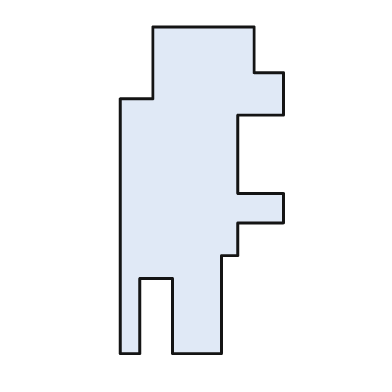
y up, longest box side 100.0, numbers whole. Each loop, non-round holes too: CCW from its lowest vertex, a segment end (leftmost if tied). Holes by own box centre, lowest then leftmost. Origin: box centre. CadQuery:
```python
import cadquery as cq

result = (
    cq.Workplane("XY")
    .moveTo(-25.0, -50.0)
    .lineTo(-19.0, -50.0)
    .lineTo(-19.0, -27.0)
    .lineTo(-9.0, -27.0)
    .lineTo(-9.0, -50.0)
    .lineTo(6.0, -50.0)
    .lineTo(6.0, -20.0)
    .lineTo(11.0, -20.0)
    .lineTo(11.0, -10.0)
    .lineTo(25.0, -10.0)
    .lineTo(25.0, -1.0)
    .lineTo(11.0, -1.0)
    .lineTo(11.0, 23.0)
    .lineTo(25.0, 23.0)
    .lineTo(25.0, 36.0)
    .lineTo(16.0, 36.0)
    .lineTo(16.0, 50.0)
    .lineTo(-15.0, 50.0)
    .lineTo(-15.0, 28.0)
    .lineTo(-25.0, 28.0)
    .close()
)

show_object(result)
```